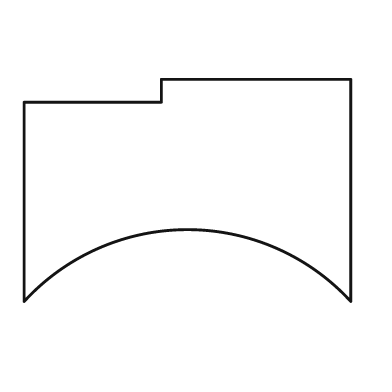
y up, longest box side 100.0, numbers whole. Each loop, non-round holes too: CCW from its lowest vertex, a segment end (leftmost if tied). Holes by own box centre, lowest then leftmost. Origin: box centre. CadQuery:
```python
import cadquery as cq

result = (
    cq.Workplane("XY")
    .moveTo(-50.0, -34.0)
    .threePointArc((0.0, -12.0), (50.0, -34.0))
    .lineTo(50.0, 34.0)
    .lineTo(-8.0, 34.0)
    .lineTo(-8.0, 27.0)
    .lineTo(-50.0, 27.0)
    .close()
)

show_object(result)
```